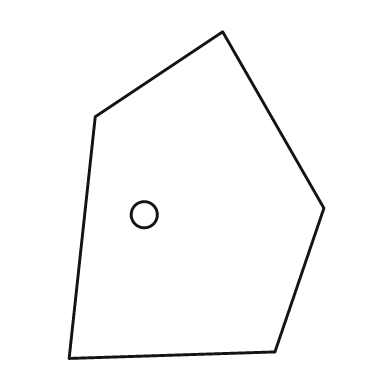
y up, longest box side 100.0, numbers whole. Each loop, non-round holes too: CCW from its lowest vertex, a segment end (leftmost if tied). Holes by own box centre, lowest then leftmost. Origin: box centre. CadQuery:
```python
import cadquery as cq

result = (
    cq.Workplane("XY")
    .moveTo(-39.0, -50.0)
    .lineTo(24.0, -48.0)
    .lineTo(39.0, -4.0)
    .lineTo(8.0, 50.0)
    .lineTo(-31.0, 24.0)
    .close()
    .moveTo(-16.0, -6.0)
    .circle(4.0)
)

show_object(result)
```